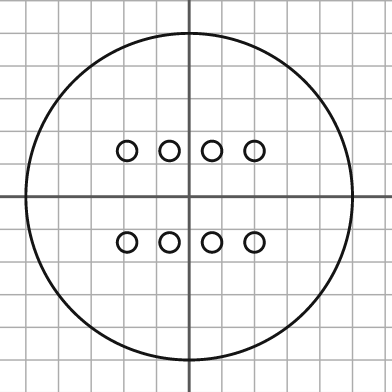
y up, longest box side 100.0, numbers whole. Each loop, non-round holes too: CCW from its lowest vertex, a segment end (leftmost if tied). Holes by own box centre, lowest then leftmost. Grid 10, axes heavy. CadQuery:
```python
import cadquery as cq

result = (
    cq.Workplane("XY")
    .moveTo(0.0, 0.0)
    .circle(50.0)
    .moveTo(-19.0, -14.0)
    .circle(3.0)
    .moveTo(-6.0, -14.0)
    .circle(3.0)
    .moveTo(7.0, -14.0)
    .circle(3.0)
    .moveTo(20.0, -14.0)
    .circle(3.0)
    .moveTo(-19.0, 14.0)
    .circle(3.0)
    .moveTo(-6.0, 14.0)
    .circle(3.0)
    .moveTo(7.0, 14.0)
    .circle(3.0)
    .moveTo(20.0, 14.0)
    .circle(3.0)
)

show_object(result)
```